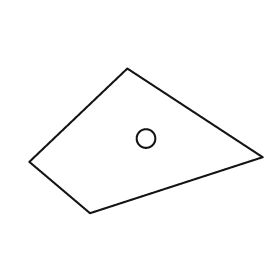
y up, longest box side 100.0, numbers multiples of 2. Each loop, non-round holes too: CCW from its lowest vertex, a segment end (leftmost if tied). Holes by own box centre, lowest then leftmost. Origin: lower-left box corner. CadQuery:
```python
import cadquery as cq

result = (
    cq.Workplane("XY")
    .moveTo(26.0, 0.0)
    .lineTo(100.0, 24.0)
    .lineTo(42.0, 62.0)
    .lineTo(0.0, 22.0)
    .close()
    .moveTo(50.0, 32.0)
    .circle(4.0)
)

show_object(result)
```